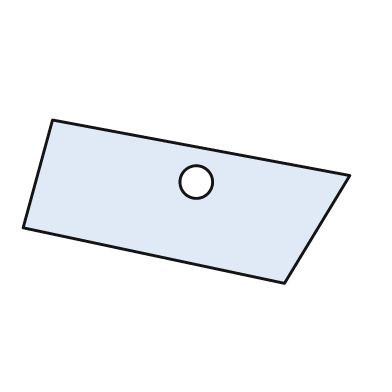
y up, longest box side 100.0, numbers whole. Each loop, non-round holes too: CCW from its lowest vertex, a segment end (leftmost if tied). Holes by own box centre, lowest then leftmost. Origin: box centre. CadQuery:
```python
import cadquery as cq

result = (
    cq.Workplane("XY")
    .moveTo(30.0, -25.0)
    .lineTo(50.0, 8.0)
    .lineTo(-41.0, 25.0)
    .lineTo(-50.0, -8.0)
    .close()
    .moveTo(3.0, 6.0)
    .circle(5.0)
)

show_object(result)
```